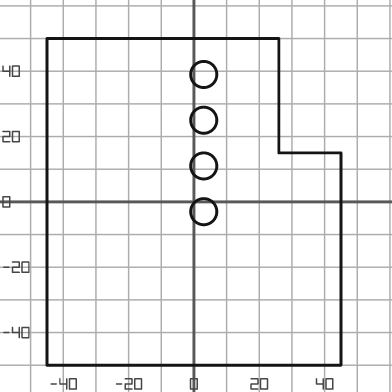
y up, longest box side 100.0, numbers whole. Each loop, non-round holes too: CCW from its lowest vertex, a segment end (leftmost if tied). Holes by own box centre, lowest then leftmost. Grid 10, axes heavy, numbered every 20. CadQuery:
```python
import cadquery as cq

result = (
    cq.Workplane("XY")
    .moveTo(-45.0, -50.0)
    .lineTo(45.0, -50.0)
    .lineTo(45.0, 15.0)
    .lineTo(26.0, 15.0)
    .lineTo(26.0, 50.0)
    .lineTo(-45.0, 50.0)
    .close()
    .moveTo(3.0, -3.0)
    .circle(4.0)
    .moveTo(3.0, 11.0)
    .circle(4.0)
    .moveTo(3.0, 25.0)
    .circle(4.0)
    .moveTo(3.0, 39.0)
    .circle(4.0)
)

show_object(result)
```